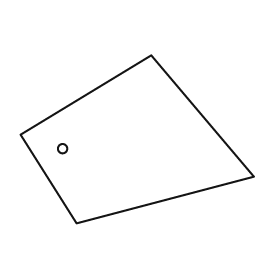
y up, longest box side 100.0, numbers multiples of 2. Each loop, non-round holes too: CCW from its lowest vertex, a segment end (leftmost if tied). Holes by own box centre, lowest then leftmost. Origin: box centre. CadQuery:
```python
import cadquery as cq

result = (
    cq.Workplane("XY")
    .moveTo(-26.0, -36.0)
    .lineTo(50.0, -16.0)
    .lineTo(6.0, 36.0)
    .lineTo(-50.0, 2.0)
    .close()
    .moveTo(-32.0, -4.0)
    .circle(2.0)
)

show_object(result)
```